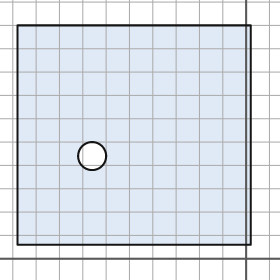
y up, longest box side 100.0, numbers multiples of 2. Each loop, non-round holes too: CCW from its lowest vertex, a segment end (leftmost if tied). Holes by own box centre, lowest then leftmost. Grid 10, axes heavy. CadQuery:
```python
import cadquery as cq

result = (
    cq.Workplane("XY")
    .moveTo(-98.0, 6.0)
    .lineTo(2.0, 6.0)
    .lineTo(2.0, 100.0)
    .lineTo(-98.0, 100.0)
    .close()
    .moveTo(-66.0, 44.0)
    .circle(6.0)
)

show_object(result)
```